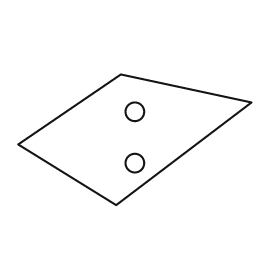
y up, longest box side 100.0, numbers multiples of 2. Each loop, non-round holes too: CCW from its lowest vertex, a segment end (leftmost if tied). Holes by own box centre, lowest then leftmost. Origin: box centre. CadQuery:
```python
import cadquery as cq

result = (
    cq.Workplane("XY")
    .moveTo(-8.0, -28.0)
    .lineTo(50.0, 16.0)
    .lineTo(-6.0, 28.0)
    .lineTo(-50.0, -2.0)
    .close()
    .moveTo(0.0, -10.0)
    .circle(4.0)
    .moveTo(0.0, 12.0)
    .circle(4.0)
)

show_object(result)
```